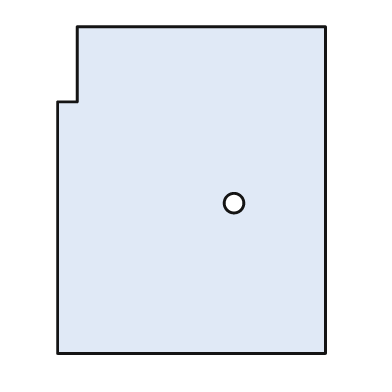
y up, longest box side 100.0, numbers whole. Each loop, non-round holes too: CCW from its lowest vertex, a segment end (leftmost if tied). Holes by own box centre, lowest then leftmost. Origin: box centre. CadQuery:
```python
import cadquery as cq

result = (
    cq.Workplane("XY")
    .moveTo(-41.0, -50.0)
    .lineTo(41.0, -50.0)
    .lineTo(41.0, 50.0)
    .lineTo(-35.0, 50.0)
    .lineTo(-35.0, 27.0)
    .lineTo(-41.0, 27.0)
    .close()
    .moveTo(13.0, -4.0)
    .circle(3.0)
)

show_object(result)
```